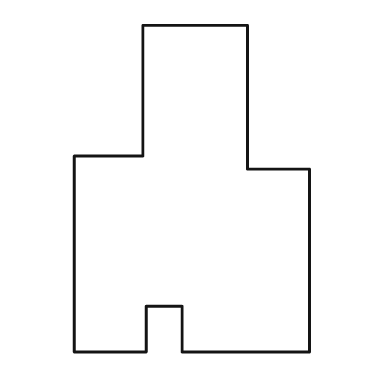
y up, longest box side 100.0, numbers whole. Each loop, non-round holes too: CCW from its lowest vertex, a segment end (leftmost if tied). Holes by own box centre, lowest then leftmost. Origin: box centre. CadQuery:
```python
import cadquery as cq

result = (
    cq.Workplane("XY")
    .moveTo(-36.0, -50.0)
    .lineTo(-14.0, -50.0)
    .lineTo(-14.0, -36.0)
    .lineTo(-3.0, -36.0)
    .lineTo(-3.0, -50.0)
    .lineTo(36.0, -50.0)
    .lineTo(36.0, 6.0)
    .lineTo(17.0, 6.0)
    .lineTo(17.0, 50.0)
    .lineTo(-15.0, 50.0)
    .lineTo(-15.0, 10.0)
    .lineTo(-36.0, 10.0)
    .close()
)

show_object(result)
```